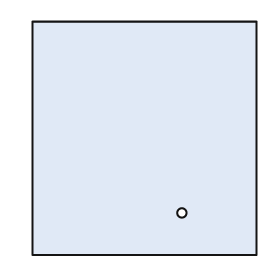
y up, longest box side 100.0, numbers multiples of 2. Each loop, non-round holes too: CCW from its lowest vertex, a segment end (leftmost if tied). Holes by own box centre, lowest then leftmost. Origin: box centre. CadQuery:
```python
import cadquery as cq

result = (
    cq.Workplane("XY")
    .moveTo(-48.0, -50.0)
    .lineTo(48.0, -50.0)
    .lineTo(48.0, 50.0)
    .lineTo(-48.0, 50.0)
    .close()
    .moveTo(16.0, -32.0)
    .circle(2.0)
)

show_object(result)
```